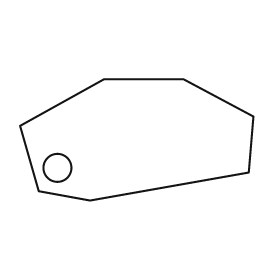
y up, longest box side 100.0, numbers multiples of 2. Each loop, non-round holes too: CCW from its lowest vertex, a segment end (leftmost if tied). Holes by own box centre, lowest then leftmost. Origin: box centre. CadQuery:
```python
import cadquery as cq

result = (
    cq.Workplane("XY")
    .moveTo(-20.0, -26.0)
    .lineTo(48.0, -14.0)
    .lineTo(50.0, 10.0)
    .lineTo(20.0, 26.0)
    .lineTo(-14.0, 26.0)
    .lineTo(-50.0, 6.0)
    .lineTo(-42.0, -22.0)
    .close()
    .moveTo(-34.0, -12.0)
    .circle(6.0)
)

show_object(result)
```